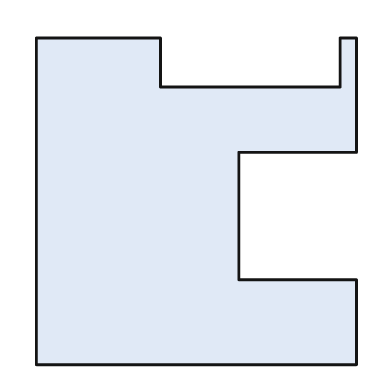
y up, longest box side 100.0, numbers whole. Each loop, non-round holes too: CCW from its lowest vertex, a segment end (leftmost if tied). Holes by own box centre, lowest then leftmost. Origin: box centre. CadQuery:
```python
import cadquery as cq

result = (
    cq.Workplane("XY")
    .moveTo(-49.0, -50.0)
    .lineTo(49.0, -50.0)
    .lineTo(49.0, -24.0)
    .lineTo(13.0, -24.0)
    .lineTo(13.0, 15.0)
    .lineTo(49.0, 15.0)
    .lineTo(49.0, 50.0)
    .lineTo(44.0, 50.0)
    .lineTo(44.0, 35.0)
    .lineTo(-11.0, 35.0)
    .lineTo(-11.0, 50.0)
    .lineTo(-49.0, 50.0)
    .close()
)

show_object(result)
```